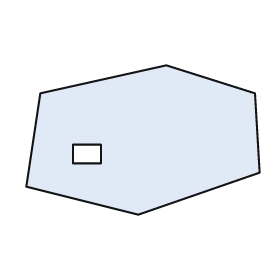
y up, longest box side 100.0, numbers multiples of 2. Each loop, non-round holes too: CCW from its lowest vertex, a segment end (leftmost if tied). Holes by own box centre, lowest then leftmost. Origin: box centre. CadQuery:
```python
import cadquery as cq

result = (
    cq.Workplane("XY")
    .moveTo(-2.0, -32.0)
    .lineTo(50.0, -14.0)
    .lineTo(48.0, 20.0)
    .lineTo(10.0, 32.0)
    .lineTo(-44.0, 20.0)
    .lineTo(-50.0, -20.0)
    .close()
    .moveTo(-30.0, -10.0)
    .lineTo(-18.0, -10.0)
    .lineTo(-18.0, -2.0)
    .lineTo(-30.0, -2.0)
    .close()
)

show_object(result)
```